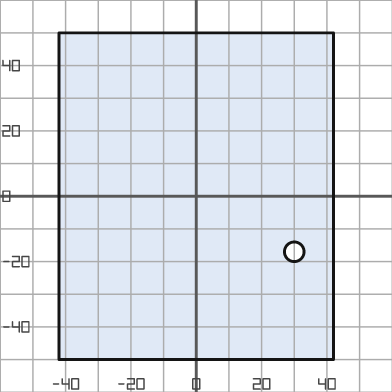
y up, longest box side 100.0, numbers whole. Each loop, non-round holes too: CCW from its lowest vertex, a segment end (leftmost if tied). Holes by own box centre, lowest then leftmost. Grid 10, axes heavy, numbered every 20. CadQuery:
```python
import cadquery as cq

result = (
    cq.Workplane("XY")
    .moveTo(-42.0, -50.0)
    .lineTo(42.0, -50.0)
    .lineTo(42.0, 50.0)
    .lineTo(-42.0, 50.0)
    .close()
    .moveTo(30.0, -17.0)
    .circle(3.0)
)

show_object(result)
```